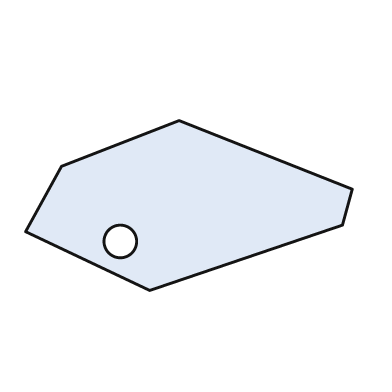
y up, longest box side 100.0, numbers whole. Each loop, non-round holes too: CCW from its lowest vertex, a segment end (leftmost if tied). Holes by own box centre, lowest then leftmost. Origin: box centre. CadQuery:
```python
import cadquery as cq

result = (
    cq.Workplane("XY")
    .moveTo(-12.0, -26.0)
    .lineTo(47.0, -6.0)
    .lineTo(50.0, 5.0)
    .lineTo(-3.0, 26.0)
    .lineTo(-39.0, 12.0)
    .lineTo(-50.0, -8.0)
    .close()
    .moveTo(-21.0, -11.0)
    .circle(5.0)
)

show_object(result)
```